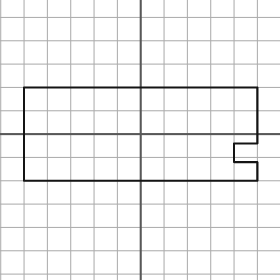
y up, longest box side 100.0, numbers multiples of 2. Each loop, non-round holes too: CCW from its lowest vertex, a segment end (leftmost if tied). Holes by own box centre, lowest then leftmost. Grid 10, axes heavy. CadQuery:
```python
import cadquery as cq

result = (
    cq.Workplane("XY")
    .moveTo(-50.0, -20.0)
    .lineTo(50.0, -20.0)
    .lineTo(50.0, -12.0)
    .lineTo(40.0, -12.0)
    .lineTo(40.0, -4.0)
    .lineTo(50.0, -4.0)
    .lineTo(50.0, 20.0)
    .lineTo(-50.0, 20.0)
    .close()
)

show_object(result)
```